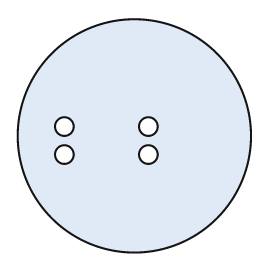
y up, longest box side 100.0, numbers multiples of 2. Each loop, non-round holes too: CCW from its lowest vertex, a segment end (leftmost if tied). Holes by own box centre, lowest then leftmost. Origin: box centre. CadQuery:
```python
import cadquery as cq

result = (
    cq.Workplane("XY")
    .moveTo(0.0, 0.0)
    .circle(50.0)
    .moveTo(-30.0, -8.0)
    .circle(4.0)
    .moveTo(6.0, -8.0)
    .circle(4.0)
    .moveTo(-30.0, 4.0)
    .circle(4.0)
    .moveTo(6.0, 4.0)
    .circle(4.0)
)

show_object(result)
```